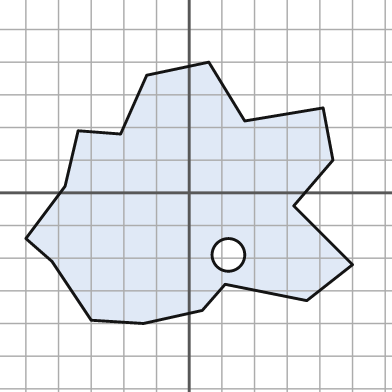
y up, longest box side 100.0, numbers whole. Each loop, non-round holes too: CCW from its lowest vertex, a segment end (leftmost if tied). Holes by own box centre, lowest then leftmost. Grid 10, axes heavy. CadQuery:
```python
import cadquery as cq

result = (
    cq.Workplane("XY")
    .moveTo(-14.0, -40.0)
    .lineTo(4.0, -36.0)
    .lineTo(11.0, -28.0)
    .lineTo(36.0, -33.0)
    .lineTo(50.0, -22.0)
    .lineTo(32.0, -4.0)
    .lineTo(44.0, 10.0)
    .lineTo(41.0, 26.0)
    .lineTo(17.0, 22.0)
    .lineTo(6.0, 40.0)
    .lineTo(-13.0, 36.0)
    .lineTo(-21.0, 18.0)
    .lineTo(-34.0, 19.0)
    .lineTo(-38.0, 2.0)
    .lineTo(-50.0, -14.0)
    .lineTo(-42.0, -21.0)
    .lineTo(-30.0, -39.0)
    .close()
    .moveTo(12.0, -19.0)
    .circle(5.0)
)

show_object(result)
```